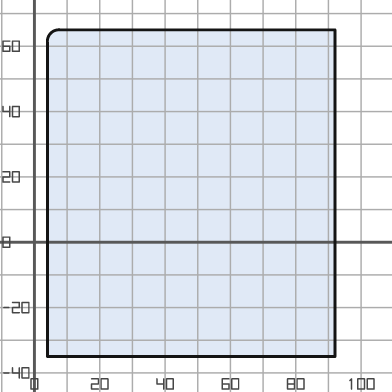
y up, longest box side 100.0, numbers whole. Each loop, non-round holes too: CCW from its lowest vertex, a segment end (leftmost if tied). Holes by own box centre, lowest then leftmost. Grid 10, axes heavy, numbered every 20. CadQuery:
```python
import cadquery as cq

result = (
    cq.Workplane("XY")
    .moveTo(4.0, -35.0)
    .lineTo(92.0, -35.0)
    .lineTo(92.0, 65.0)
    .lineTo(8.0, 65.0)
    .threePointArc((5.0, 64.0), (4.0, 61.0))
    .close()
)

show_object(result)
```